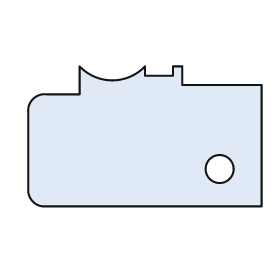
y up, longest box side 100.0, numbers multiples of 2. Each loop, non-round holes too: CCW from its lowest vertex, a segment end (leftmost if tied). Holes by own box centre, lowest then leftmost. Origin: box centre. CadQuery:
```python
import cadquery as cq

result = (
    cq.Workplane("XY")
    .moveTo(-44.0, -30.0)
    .lineTo(50.0, -30.0)
    .lineTo(50.0, 22.0)
    .lineTo(16.0, 22.0)
    .lineTo(16.0, 30.0)
    .lineTo(12.0, 30.0)
    .lineTo(12.0, 26.0)
    .lineTo(0.0, 26.0)
    .lineTo(0.0, 30.0)
    .threePointArc((-14.0, 24.0), (-28.0, 30.0))
    .lineTo(-28.0, 18.0)
    .lineTo(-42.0, 18.0)
    .threePointArc((-48.0, 16.0), (-50.0, 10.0))
    .lineTo(-50.0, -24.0)
    .threePointArc((-48.0, -28.0), (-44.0, -30.0))
    .close()
    .moveTo(32.0, -14.0)
    .circle(6.0)
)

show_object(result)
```